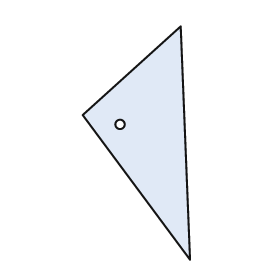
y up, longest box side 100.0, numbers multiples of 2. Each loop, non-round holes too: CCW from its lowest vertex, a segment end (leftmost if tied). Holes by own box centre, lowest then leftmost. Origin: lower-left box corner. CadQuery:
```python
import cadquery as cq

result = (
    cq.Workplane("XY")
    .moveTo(46.0, 0.0)
    .lineTo(42.0, 100.0)
    .lineTo(0.0, 62.0)
    .close()
    .moveTo(16.0, 58.0)
    .circle(2.0)
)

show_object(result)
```